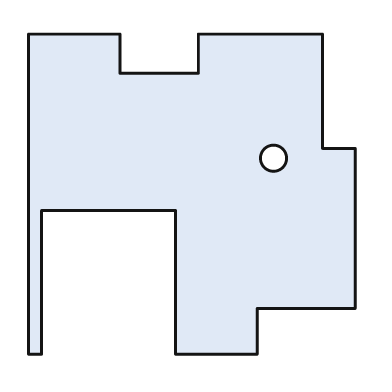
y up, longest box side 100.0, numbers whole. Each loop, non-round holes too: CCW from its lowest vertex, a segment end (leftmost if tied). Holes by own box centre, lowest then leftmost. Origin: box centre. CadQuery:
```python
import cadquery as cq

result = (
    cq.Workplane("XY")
    .moveTo(-50.0, -49.0)
    .lineTo(-46.0, -49.0)
    .lineTo(-46.0, -5.0)
    .lineTo(-5.0, -5.0)
    .lineTo(-5.0, -49.0)
    .lineTo(20.0, -49.0)
    .lineTo(20.0, -35.0)
    .lineTo(50.0, -35.0)
    .lineTo(50.0, 14.0)
    .lineTo(40.0, 14.0)
    .lineTo(40.0, 49.0)
    .lineTo(2.0, 49.0)
    .lineTo(2.0, 37.0)
    .lineTo(-22.0, 37.0)
    .lineTo(-22.0, 49.0)
    .lineTo(-50.0, 49.0)
    .close()
    .moveTo(25.0, 11.0)
    .circle(4.0)
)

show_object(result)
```